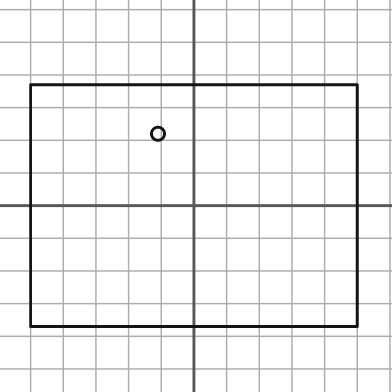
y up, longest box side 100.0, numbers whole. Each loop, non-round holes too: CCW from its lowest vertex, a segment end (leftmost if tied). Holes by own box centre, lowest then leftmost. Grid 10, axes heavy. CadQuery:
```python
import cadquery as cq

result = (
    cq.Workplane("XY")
    .moveTo(-50.0, -37.0)
    .lineTo(50.0, -37.0)
    .lineTo(50.0, 37.0)
    .lineTo(-50.0, 37.0)
    .close()
    .moveTo(-11.0, 22.0)
    .circle(2.0)
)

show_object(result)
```